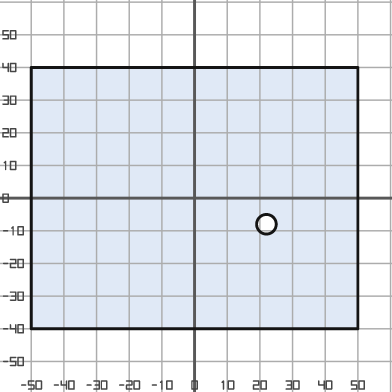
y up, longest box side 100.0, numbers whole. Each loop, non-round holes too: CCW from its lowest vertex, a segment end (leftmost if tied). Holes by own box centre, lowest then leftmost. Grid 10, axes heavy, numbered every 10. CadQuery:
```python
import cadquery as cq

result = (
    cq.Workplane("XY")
    .moveTo(-50.0, -40.0)
    .lineTo(50.0, -40.0)
    .lineTo(50.0, 40.0)
    .lineTo(-50.0, 40.0)
    .close()
    .moveTo(22.0, -8.0)
    .circle(3.0)
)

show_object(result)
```